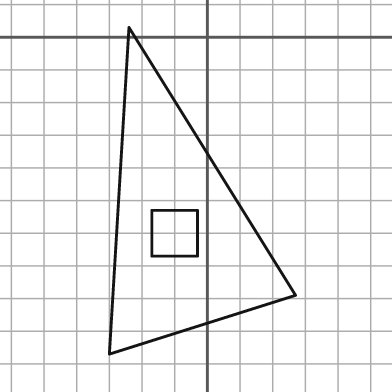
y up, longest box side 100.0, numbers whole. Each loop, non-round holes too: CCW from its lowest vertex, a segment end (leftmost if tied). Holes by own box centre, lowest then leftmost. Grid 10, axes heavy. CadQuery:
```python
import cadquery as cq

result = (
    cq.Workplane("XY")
    .moveTo(-30.0, -97.0)
    .lineTo(27.0, -79.0)
    .lineTo(-24.0, 3.0)
    .close()
    .moveTo(-17.0, -67.0)
    .lineTo(-3.0, -67.0)
    .lineTo(-3.0, -53.0)
    .lineTo(-17.0, -53.0)
    .close()
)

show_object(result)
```